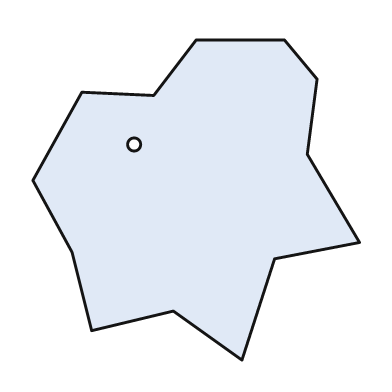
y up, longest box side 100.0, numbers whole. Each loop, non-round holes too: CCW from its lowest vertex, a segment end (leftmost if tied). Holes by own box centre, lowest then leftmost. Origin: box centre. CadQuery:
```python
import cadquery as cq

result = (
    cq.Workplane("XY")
    .moveTo(14.0, -49.0)
    .lineTo(24.0, -18.0)
    .lineTo(50.0, -13.0)
    .lineTo(34.0, 14.0)
    .lineTo(37.0, 37.0)
    .lineTo(27.0, 49.0)
    .lineTo(0.0, 49.0)
    .lineTo(-13.0, 32.0)
    .lineTo(-35.0, 33.0)
    .lineTo(-50.0, 6.0)
    .lineTo(-38.0, -16.0)
    .lineTo(-32.0, -40.0)
    .lineTo(-7.0, -34.0)
    .close()
    .moveTo(-19.0, 17.0)
    .circle(2.0)
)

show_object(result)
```